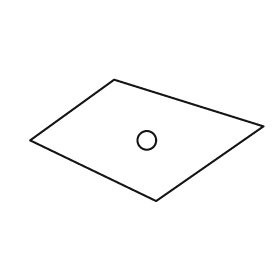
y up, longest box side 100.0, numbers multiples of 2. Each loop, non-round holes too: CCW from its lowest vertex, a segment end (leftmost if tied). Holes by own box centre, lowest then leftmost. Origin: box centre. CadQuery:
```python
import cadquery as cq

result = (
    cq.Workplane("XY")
    .moveTo(4.0, -26.0)
    .lineTo(50.0, 6.0)
    .lineTo(-14.0, 26.0)
    .lineTo(-50.0, 0.0)
    .close()
    .moveTo(0.0, 0.0)
    .circle(4.0)
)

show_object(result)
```